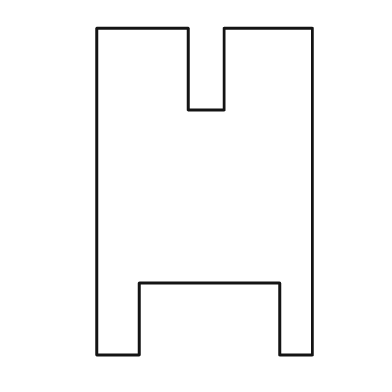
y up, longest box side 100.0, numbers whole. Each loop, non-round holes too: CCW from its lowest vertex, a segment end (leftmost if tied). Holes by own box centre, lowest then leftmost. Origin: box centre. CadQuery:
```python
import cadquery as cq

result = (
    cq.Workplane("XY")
    .moveTo(-33.0, -50.0)
    .lineTo(-20.0, -50.0)
    .lineTo(-20.0, -28.0)
    .lineTo(23.0, -28.0)
    .lineTo(23.0, -50.0)
    .lineTo(33.0, -50.0)
    .lineTo(33.0, 50.0)
    .lineTo(6.0, 50.0)
    .lineTo(6.0, 25.0)
    .lineTo(-5.0, 25.0)
    .lineTo(-5.0, 50.0)
    .lineTo(-33.0, 50.0)
    .close()
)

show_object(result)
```